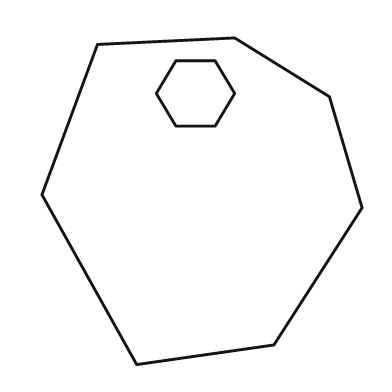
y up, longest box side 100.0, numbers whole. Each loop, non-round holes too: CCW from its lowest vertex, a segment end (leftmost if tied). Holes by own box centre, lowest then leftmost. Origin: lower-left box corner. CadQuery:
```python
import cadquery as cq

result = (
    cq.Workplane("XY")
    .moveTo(29.0, 0.0)
    .lineTo(71.0, 6.0)
    .lineTo(98.0, 48.0)
    .lineTo(88.0, 82.0)
    .lineTo(59.0, 100.0)
    .lineTo(17.0, 98.0)
    .lineTo(0.0, 52.0)
    .close()
    .moveTo(41.0, 73.0)
    .lineTo(53.0, 73.0)
    .lineTo(59.0, 83.0)
    .lineTo(53.0, 93.0)
    .lineTo(41.0, 93.0)
    .lineTo(35.0, 83.0)
    .close()
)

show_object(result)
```